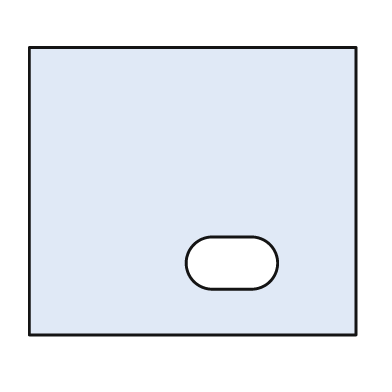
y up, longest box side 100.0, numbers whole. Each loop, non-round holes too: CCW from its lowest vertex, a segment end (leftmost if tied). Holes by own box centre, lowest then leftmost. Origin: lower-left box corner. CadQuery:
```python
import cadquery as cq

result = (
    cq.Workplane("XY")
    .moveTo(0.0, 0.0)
    .lineTo(100.0, 0.0)
    .lineTo(100.0, 88.0)
    .lineTo(0.0, 88.0)
    .close()
    .moveTo(56.0, 14.0)
    .lineTo(68.0, 14.0)
    .threePointArc((76.0, 22.0), (68.0, 30.0))
    .lineTo(56.0, 30.0)
    .threePointArc((48.0, 22.0), (56.0, 14.0))
    .close()
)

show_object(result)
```